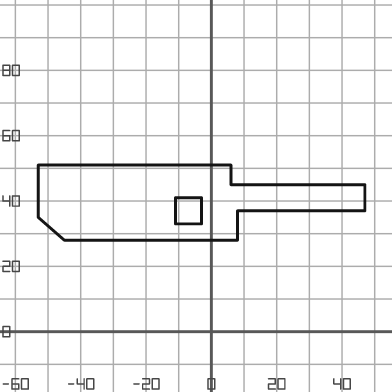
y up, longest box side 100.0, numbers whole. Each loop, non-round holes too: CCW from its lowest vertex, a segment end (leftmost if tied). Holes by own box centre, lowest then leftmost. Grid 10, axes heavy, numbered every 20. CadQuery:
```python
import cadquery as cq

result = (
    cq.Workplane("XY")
    .moveTo(-45.0, 28.0)
    .lineTo(8.0, 28.0)
    .lineTo(8.0, 37.0)
    .lineTo(47.0, 37.0)
    .lineTo(47.0, 45.0)
    .lineTo(6.0, 45.0)
    .lineTo(6.0, 51.0)
    .lineTo(-53.0, 51.0)
    .lineTo(-53.0, 35.0)
    .close()
    .moveTo(-11.0, 33.0)
    .lineTo(-3.0, 33.0)
    .lineTo(-3.0, 41.0)
    .lineTo(-11.0, 41.0)
    .close()
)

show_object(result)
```